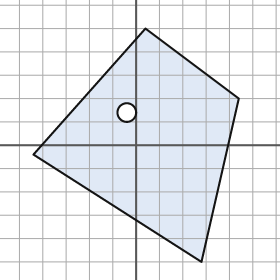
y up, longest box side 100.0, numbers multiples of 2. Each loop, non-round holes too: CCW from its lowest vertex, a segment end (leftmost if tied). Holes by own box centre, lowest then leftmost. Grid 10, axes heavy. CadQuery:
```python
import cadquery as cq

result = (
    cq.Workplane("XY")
    .moveTo(28.0, -50.0)
    .lineTo(44.0, 20.0)
    .lineTo(4.0, 50.0)
    .lineTo(-44.0, -4.0)
    .close()
    .moveTo(-4.0, 14.0)
    .circle(4.0)
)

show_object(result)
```